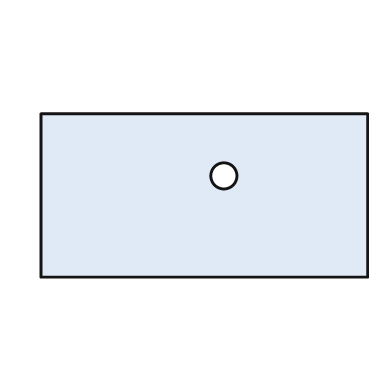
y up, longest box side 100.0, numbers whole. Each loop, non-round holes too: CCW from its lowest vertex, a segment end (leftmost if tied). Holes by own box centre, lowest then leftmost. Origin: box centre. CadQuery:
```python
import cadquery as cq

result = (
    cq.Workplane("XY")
    .moveTo(-50.0, -25.0)
    .lineTo(50.0, -25.0)
    .lineTo(50.0, 25.0)
    .lineTo(-50.0, 25.0)
    .close()
    .moveTo(6.0, 6.0)
    .circle(4.0)
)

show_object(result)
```